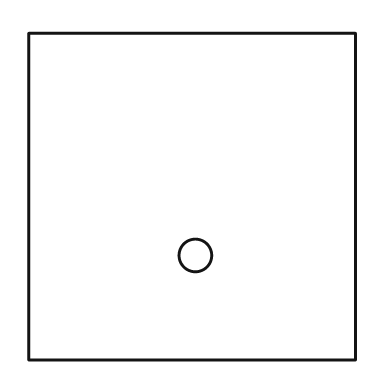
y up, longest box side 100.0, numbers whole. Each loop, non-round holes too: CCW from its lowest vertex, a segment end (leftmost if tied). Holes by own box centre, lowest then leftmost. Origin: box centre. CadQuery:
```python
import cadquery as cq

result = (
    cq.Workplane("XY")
    .moveTo(-50.0, -50.0)
    .lineTo(50.0, -50.0)
    .lineTo(50.0, 50.0)
    .lineTo(-50.0, 50.0)
    .close()
    .moveTo(1.0, -18.0)
    .circle(5.0)
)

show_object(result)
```